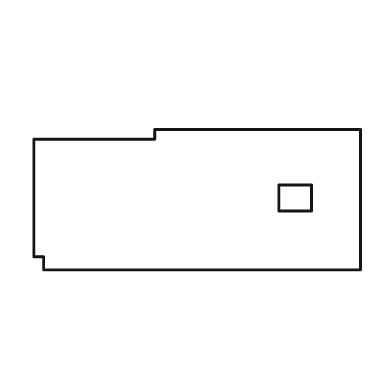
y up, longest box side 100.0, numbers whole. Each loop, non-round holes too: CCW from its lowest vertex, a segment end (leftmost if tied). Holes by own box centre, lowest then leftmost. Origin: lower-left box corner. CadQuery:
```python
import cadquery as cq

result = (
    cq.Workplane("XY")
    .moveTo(3.0, 0.0)
    .lineTo(100.0, 0.0)
    .lineTo(100.0, 43.0)
    .lineTo(37.0, 43.0)
    .lineTo(37.0, 40.0)
    .lineTo(0.0, 40.0)
    .lineTo(0.0, 4.0)
    .lineTo(3.0, 4.0)
    .close()
    .moveTo(75.0, 18.0)
    .lineTo(85.0, 18.0)
    .lineTo(85.0, 26.0)
    .lineTo(75.0, 26.0)
    .close()
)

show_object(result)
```